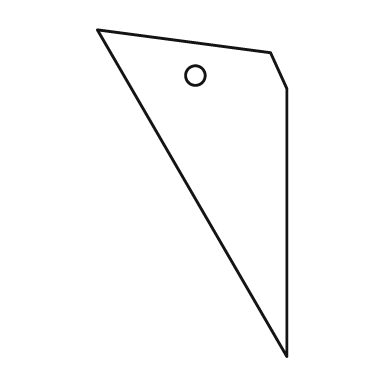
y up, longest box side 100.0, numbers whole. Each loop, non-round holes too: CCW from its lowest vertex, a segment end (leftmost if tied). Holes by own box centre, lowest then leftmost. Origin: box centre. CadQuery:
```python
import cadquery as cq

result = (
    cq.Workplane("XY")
    .moveTo(29.0, -50.0)
    .lineTo(29.0, 32.0)
    .lineTo(24.0, 43.0)
    .lineTo(-29.0, 50.0)
    .close()
    .moveTo(1.0, 36.0)
    .circle(3.0)
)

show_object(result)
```